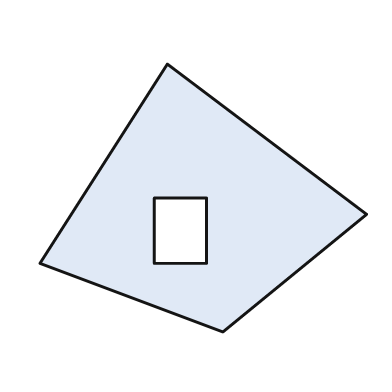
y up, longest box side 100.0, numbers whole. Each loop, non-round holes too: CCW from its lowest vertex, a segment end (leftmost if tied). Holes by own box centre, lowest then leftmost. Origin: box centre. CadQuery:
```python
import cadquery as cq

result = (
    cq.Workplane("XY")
    .moveTo(6.0, -41.0)
    .lineTo(50.0, -5.0)
    .lineTo(-11.0, 41.0)
    .lineTo(-50.0, -20.0)
    .close()
    .moveTo(-15.0, -20.0)
    .lineTo(1.0, -20.0)
    .lineTo(1.0, 0.0)
    .lineTo(-15.0, 0.0)
    .close()
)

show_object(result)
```